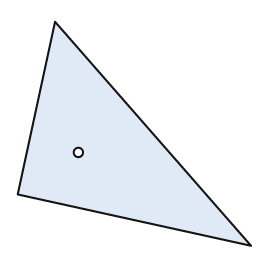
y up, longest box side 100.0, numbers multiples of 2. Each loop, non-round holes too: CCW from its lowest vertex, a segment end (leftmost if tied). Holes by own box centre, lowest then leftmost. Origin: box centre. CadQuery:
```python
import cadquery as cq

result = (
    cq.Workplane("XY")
    .moveTo(50.0, -48.0)
    .lineTo(-34.0, 48.0)
    .lineTo(-50.0, -26.0)
    .close()
    .moveTo(-24.0, -8.0)
    .circle(2.0)
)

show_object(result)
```